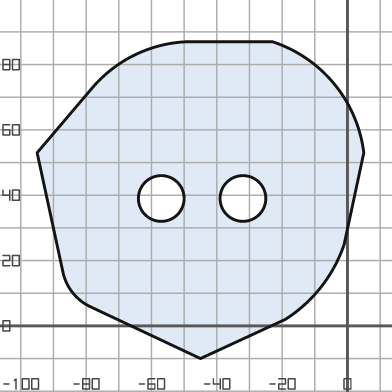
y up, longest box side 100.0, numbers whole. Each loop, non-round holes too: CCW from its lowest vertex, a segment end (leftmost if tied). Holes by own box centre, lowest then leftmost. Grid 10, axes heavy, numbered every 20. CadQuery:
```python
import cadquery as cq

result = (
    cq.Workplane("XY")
    .moveTo(-45.0, -10.0)
    .lineTo(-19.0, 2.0)
    .threePointArc((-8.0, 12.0), (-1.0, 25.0))
    .lineTo(5.0, 53.0)
    .threePointArc((-4.0, 74.0), (-23.0, 87.0))
    .lineTo(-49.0, 87.0)
    .threePointArc((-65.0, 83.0), (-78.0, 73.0))
    .lineTo(-95.0, 53.0)
    .lineTo(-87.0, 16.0)
    .threePointArc((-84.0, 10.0), (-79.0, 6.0))
    .close()
    .moveTo(-57.0, 39.0)
    .circle(7.0)
    .moveTo(-32.0, 39.0)
    .circle(7.0)
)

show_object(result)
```